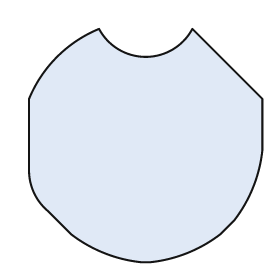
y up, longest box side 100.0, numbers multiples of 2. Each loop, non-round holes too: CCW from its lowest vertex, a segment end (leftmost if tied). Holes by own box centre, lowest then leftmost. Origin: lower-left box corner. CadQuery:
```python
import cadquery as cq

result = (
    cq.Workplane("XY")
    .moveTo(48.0, 0.0)
    .lineTo(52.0, 0.0)
    .threePointArc((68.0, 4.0), (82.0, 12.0))
    .lineTo(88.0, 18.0)
    .threePointArc((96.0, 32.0), (100.0, 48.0))
    .lineTo(100.0, 70.0)
    .lineTo(70.0, 100.0)
    .threePointArc((50.0, 88.0), (30.0, 100.0))
    .threePointArc((12.0, 88.0), (0.0, 70.0))
    .lineTo(0.0, 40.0)
    .threePointArc((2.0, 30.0), (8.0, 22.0))
    .lineTo(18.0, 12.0)
    .threePointArc((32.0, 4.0), (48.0, 0.0))
    .close()
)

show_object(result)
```